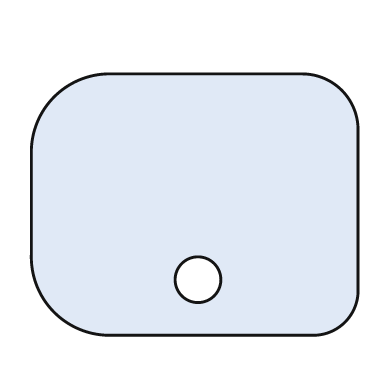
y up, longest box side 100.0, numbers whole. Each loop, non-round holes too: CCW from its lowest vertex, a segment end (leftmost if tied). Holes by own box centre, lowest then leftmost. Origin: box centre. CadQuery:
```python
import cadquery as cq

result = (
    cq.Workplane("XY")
    .moveTo(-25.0, -40.0)
    .lineTo(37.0, -40.0)
    .threePointArc((46.0, -36.0), (50.0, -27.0))
    .lineTo(50.0, 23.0)
    .threePointArc((45.0, 35.0), (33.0, 40.0))
    .lineTo(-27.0, 40.0)
    .threePointArc((-43.0, 33.0), (-50.0, 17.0))
    .lineTo(-50.0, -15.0)
    .threePointArc((-43.0, -33.0), (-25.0, -40.0))
    .close()
    .moveTo(1.0, -23.0)
    .circle(7.0)
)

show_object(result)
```